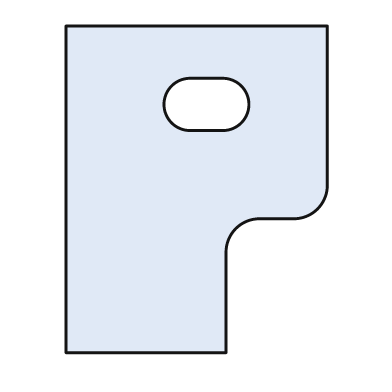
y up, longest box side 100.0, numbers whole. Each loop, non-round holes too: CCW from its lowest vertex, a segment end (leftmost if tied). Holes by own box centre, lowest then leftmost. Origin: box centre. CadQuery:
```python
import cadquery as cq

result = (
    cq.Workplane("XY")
    .moveTo(-40.0, -50.0)
    .lineTo(9.0, -50.0)
    .lineTo(9.0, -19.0)
    .threePointArc((12.0, -12.0), (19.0, -9.0))
    .lineTo(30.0, -9.0)
    .threePointArc((37.0, -6.0), (40.0, 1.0))
    .lineTo(40.0, 50.0)
    .lineTo(-40.0, 50.0)
    .close()
    .moveTo(-2.0, 18.0)
    .lineTo(8.0, 18.0)
    .threePointArc((16.0, 26.0), (8.0, 34.0))
    .lineTo(-2.0, 34.0)
    .threePointArc((-10.0, 26.0), (-2.0, 18.0))
    .close()
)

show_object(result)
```